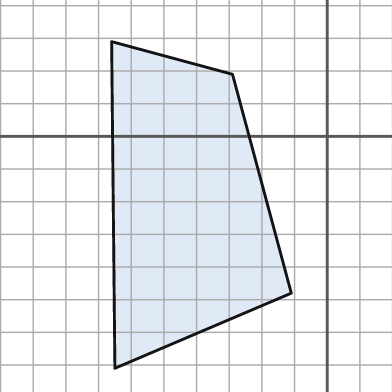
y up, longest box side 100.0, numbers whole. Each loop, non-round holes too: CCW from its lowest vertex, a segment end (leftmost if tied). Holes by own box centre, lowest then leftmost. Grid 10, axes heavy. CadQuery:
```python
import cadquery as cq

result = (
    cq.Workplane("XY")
    .moveTo(-65.0, -71.0)
    .lineTo(-11.0, -48.0)
    .lineTo(-29.0, 19.0)
    .lineTo(-66.0, 29.0)
    .close()
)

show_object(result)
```